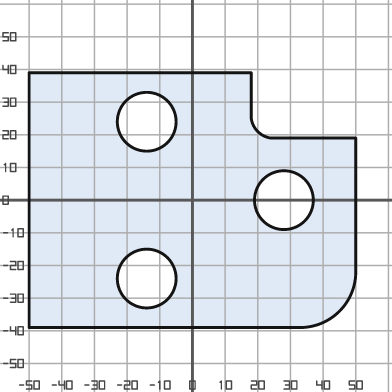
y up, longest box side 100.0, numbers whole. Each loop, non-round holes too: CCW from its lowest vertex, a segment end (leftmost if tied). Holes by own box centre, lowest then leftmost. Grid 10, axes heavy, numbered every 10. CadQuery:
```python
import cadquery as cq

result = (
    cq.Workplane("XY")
    .moveTo(-50.0, -39.0)
    .lineTo(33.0, -39.0)
    .threePointArc((45.0, -34.0), (50.0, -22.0))
    .lineTo(50.0, 19.0)
    .lineTo(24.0, 19.0)
    .threePointArc((20.0, 21.0), (18.0, 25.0))
    .lineTo(18.0, 39.0)
    .lineTo(-50.0, 39.0)
    .close()
    .moveTo(-14.0, -24.0)
    .circle(9.0)
    .moveTo(28.0, 0.0)
    .circle(9.0)
    .moveTo(-14.0, 24.0)
    .circle(9.0)
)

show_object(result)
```